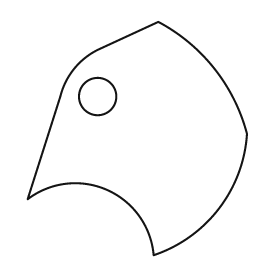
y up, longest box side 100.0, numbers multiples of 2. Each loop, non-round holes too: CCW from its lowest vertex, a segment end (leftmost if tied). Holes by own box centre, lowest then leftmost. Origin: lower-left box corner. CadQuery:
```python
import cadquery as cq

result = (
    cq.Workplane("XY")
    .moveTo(54.0, 0.0)
    .threePointArc((82.0, 20.0), (94.0, 52.0))
    .threePointArc((80.0, 80.0), (56.0, 100.0))
    .lineTo(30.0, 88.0)
    .threePointArc((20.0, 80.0), (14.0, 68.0))
    .lineTo(0.0, 24.0)
    .threePointArc((34.0, 28.0), (54.0, 0.0))
    .close()
    .moveTo(30.0, 68.0)
    .circle(8.0)
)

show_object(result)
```